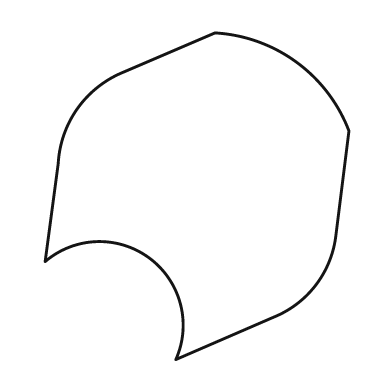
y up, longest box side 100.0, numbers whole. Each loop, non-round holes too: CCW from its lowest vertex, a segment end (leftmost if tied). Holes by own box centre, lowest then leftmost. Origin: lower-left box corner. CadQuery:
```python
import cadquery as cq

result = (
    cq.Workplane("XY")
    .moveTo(40.0, 0.0)
    .lineTo(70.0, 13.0)
    .threePointArc((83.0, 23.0), (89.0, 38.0))
    .lineTo(93.0, 70.0)
    .threePointArc((77.0, 91.0), (52.0, 100.0))
    .lineTo(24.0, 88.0)
    .threePointArc((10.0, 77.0), (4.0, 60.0))
    .lineTo(0.0, 30.0)
    .threePointArc((32.0, 31.0), (40.0, 0.0))
    .close()
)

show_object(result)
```